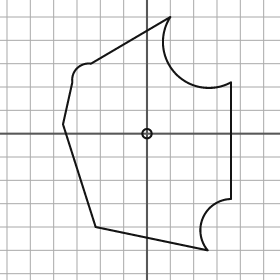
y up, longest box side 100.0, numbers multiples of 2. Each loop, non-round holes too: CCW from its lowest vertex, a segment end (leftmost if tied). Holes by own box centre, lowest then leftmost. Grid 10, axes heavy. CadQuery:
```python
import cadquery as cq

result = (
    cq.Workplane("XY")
    .moveTo(26.0, -50.0)
    .threePointArc((24.0, -36.0), (36.0, -28.0))
    .lineTo(36.0, 22.0)
    .threePointArc((12.0, 26.0), (10.0, 50.0))
    .lineTo(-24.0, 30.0)
    .threePointArc((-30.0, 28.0), (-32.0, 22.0))
    .lineTo(-36.0, 4.0)
    .lineTo(-22.0, -40.0)
    .close()
    .moveTo(0.0, 0.0)
    .circle(2.0)
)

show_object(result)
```